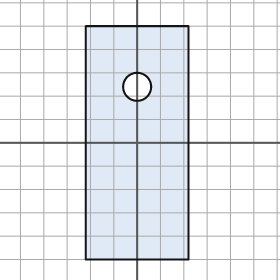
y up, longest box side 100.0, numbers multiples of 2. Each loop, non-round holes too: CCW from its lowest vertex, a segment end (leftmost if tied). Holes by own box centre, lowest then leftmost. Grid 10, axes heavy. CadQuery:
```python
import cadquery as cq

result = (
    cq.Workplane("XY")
    .moveTo(-22.0, -50.0)
    .lineTo(22.0, -50.0)
    .lineTo(22.0, 50.0)
    .lineTo(-22.0, 50.0)
    .close()
    .moveTo(0.0, 24.0)
    .circle(6.0)
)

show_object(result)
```